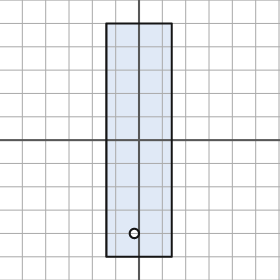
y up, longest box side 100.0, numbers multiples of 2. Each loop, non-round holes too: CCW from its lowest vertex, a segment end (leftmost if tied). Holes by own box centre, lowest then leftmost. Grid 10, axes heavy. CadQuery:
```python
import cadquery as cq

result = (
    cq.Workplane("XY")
    .moveTo(-14.0, -50.0)
    .lineTo(14.0, -50.0)
    .lineTo(14.0, 50.0)
    .lineTo(-14.0, 50.0)
    .close()
    .moveTo(-2.0, -40.0)
    .circle(2.0)
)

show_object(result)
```